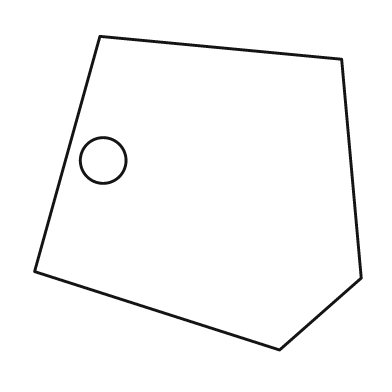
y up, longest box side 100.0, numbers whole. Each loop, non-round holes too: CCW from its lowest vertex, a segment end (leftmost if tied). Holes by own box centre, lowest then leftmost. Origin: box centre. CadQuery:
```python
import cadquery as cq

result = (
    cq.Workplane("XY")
    .moveTo(25.0, -48.0)
    .lineTo(50.0, -26.0)
    .lineTo(44.0, 41.0)
    .lineTo(-30.0, 48.0)
    .lineTo(-50.0, -24.0)
    .close()
    .moveTo(-29.0, 10.0)
    .circle(7.0)
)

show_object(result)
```